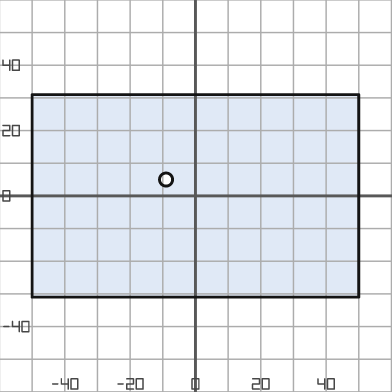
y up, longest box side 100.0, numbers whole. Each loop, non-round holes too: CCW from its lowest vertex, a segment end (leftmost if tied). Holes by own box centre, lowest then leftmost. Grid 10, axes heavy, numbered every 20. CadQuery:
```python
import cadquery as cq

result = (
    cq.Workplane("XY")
    .moveTo(-50.0, -31.0)
    .lineTo(50.0, -31.0)
    .lineTo(50.0, 31.0)
    .lineTo(-50.0, 31.0)
    .close()
    .moveTo(-9.0, 5.0)
    .circle(2.0)
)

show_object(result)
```